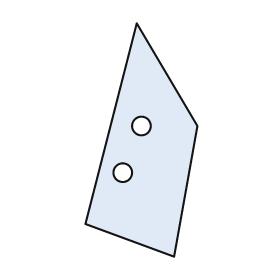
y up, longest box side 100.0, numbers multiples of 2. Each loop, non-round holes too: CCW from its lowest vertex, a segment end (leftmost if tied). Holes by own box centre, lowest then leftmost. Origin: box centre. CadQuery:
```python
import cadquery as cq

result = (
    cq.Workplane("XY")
    .moveTo(14.0, -50.0)
    .lineTo(24.0, 6.0)
    .lineTo(-2.0, 50.0)
    .lineTo(-24.0, -36.0)
    .close()
    .moveTo(-8.0, -14.0)
    .circle(4.0)
    .moveTo(0.0, 6.0)
    .circle(4.0)
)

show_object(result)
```